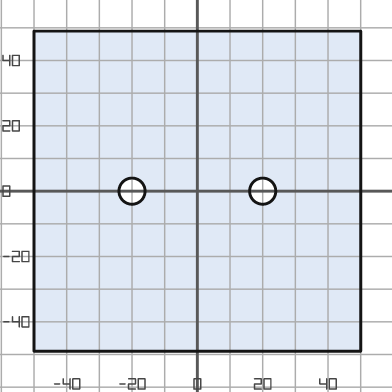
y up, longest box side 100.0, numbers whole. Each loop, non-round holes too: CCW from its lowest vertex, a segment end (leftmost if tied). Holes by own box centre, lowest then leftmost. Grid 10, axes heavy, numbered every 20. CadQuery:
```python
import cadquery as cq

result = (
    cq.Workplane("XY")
    .moveTo(-50.0, -49.0)
    .lineTo(50.0, -49.0)
    .lineTo(50.0, 49.0)
    .lineTo(-50.0, 49.0)
    .close()
    .moveTo(-20.0, 0.0)
    .circle(4.0)
    .moveTo(20.0, 0.0)
    .circle(4.0)
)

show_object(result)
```